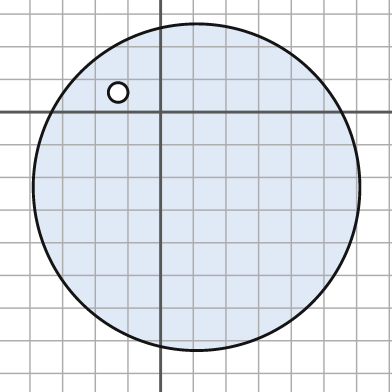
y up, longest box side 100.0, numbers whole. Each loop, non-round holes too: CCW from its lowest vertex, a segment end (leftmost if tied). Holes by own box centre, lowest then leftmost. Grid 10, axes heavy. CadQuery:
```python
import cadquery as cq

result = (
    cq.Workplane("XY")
    .moveTo(11.0, -23.0)
    .circle(50.0)
    .moveTo(-13.0, 6.0)
    .circle(3.0)
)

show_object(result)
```